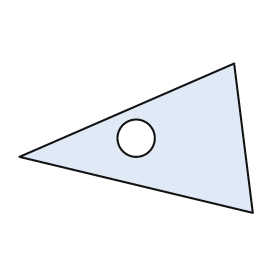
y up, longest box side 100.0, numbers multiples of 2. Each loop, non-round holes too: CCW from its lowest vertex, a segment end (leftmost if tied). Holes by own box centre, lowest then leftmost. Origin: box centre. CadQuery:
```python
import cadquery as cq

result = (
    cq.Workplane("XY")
    .moveTo(50.0, -32.0)
    .lineTo(42.0, 32.0)
    .lineTo(-50.0, -8.0)
    .close()
    .moveTo(0.0, 0.0)
    .circle(8.0)
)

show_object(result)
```